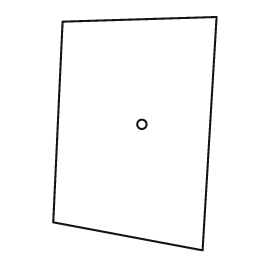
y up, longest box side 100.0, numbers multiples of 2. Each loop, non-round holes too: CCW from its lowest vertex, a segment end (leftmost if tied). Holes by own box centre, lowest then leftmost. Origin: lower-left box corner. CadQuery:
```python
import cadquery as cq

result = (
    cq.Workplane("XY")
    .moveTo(64.0, 0.0)
    .lineTo(70.0, 100.0)
    .lineTo(4.0, 98.0)
    .lineTo(0.0, 12.0)
    .close()
    .moveTo(38.0, 54.0)
    .circle(2.0)
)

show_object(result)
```